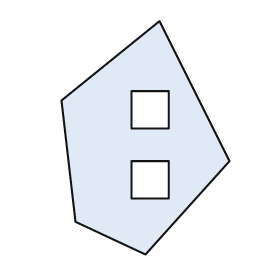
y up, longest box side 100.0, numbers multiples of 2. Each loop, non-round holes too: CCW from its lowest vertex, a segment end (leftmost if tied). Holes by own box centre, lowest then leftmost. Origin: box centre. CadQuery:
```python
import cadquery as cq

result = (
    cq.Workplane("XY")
    .moveTo(0.0, -50.0)
    .lineTo(36.0, -10.0)
    .lineTo(6.0, 50.0)
    .lineTo(-36.0, 16.0)
    .lineTo(-30.0, -36.0)
    .close()
    .moveTo(-6.0, -26.0)
    .lineTo(10.0, -26.0)
    .lineTo(10.0, -10.0)
    .lineTo(-6.0, -10.0)
    .close()
    .moveTo(-6.0, 4.0)
    .lineTo(10.0, 4.0)
    .lineTo(10.0, 20.0)
    .lineTo(-6.0, 20.0)
    .close()
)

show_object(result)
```